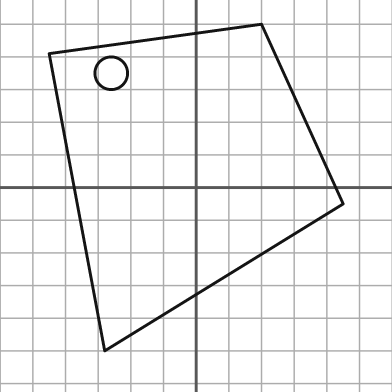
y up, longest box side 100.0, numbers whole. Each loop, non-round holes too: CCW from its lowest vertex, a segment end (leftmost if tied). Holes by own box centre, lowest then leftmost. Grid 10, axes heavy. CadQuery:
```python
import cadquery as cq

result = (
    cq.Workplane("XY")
    .moveTo(-28.0, -50.0)
    .lineTo(45.0, -5.0)
    .lineTo(20.0, 50.0)
    .lineTo(-45.0, 41.0)
    .close()
    .moveTo(-26.0, 35.0)
    .circle(5.0)
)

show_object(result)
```